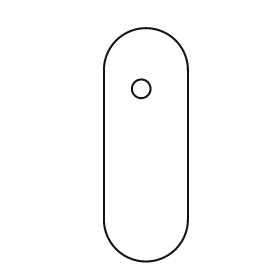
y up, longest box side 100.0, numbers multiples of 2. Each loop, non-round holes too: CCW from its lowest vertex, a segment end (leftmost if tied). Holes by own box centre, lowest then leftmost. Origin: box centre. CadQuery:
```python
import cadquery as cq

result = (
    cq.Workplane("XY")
    .moveTo(-18.0, -32.0)
    .threePointArc((0.0, -50.0), (18.0, -32.0))
    .lineTo(18.0, 32.0)
    .threePointArc((0.0, 50.0), (-18.0, 32.0))
    .close()
    .moveTo(-2.0, 24.0)
    .circle(4.0)
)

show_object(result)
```